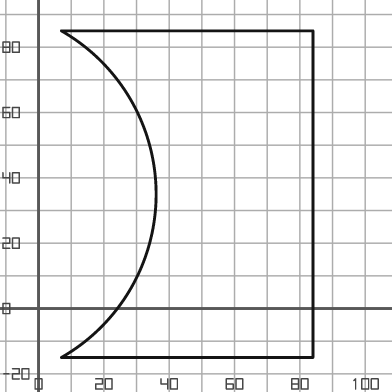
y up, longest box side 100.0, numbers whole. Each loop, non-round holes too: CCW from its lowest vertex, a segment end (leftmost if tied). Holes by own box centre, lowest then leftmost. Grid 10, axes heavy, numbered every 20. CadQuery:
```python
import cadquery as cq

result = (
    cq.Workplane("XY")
    .moveTo(7.0, -15.0)
    .lineTo(84.0, -15.0)
    .lineTo(84.0, 85.0)
    .lineTo(7.0, 85.0)
    .threePointArc((36.0, 35.0), (7.0, -15.0))
    .close()
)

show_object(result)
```